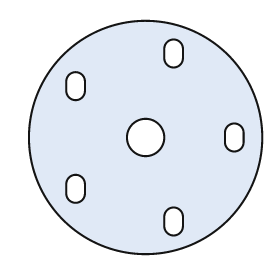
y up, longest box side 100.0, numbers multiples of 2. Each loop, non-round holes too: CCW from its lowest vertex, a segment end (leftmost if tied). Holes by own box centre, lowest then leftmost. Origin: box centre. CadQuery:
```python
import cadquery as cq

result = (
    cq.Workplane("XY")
    .moveTo(0.0, 0.0)
    .circle(50.0)
    .moveTo(8.0, -38.0)
    .threePointArc((12.0, -42.0), (16.0, -38.0))
    .lineTo(16.0, -34.0)
    .threePointArc((12.0, -30.0), (8.0, -34.0))
    .close()
    .moveTo(-34.0, -24.0)
    .threePointArc((-30.0, -28.0), (-26.0, -24.0))
    .lineTo(-26.0, -20.0)
    .threePointArc((-30.0, -16.0), (-34.0, -20.0))
    .close()
    .moveTo(0.0, 0.0)
    .circle(8.0)
    .moveTo(34.0, -2.0)
    .threePointArc((38.0, -6.0), (42.0, -2.0))
    .lineTo(42.0, 2.0)
    .threePointArc((38.0, 6.0), (34.0, 2.0))
    .close()
    .moveTo(-34.0, 20.0)
    .threePointArc((-30.0, 16.0), (-26.0, 20.0))
    .lineTo(-26.0, 24.0)
    .threePointArc((-30.0, 28.0), (-34.0, 24.0))
    .close()
    .moveTo(8.0, 34.0)
    .threePointArc((12.0, 30.0), (16.0, 34.0))
    .lineTo(16.0, 38.0)
    .threePointArc((12.0, 42.0), (8.0, 38.0))
    .close()
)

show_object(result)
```